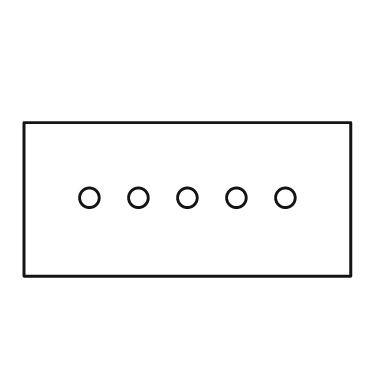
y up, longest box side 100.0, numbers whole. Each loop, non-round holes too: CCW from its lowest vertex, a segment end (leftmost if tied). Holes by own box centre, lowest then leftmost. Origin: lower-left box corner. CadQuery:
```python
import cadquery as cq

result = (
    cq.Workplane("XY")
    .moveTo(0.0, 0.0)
    .lineTo(100.0, 0.0)
    .lineTo(100.0, 47.0)
    .lineTo(0.0, 47.0)
    .close()
    .moveTo(20.0, 24.0)
    .circle(3.0)
    .moveTo(35.0, 24.0)
    .circle(3.0)
    .moveTo(50.0, 24.0)
    .circle(3.0)
    .moveTo(65.0, 24.0)
    .circle(3.0)
    .moveTo(80.0, 24.0)
    .circle(3.0)
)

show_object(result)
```